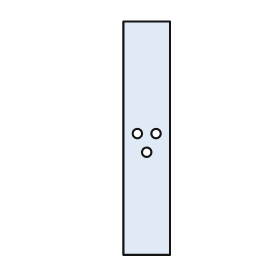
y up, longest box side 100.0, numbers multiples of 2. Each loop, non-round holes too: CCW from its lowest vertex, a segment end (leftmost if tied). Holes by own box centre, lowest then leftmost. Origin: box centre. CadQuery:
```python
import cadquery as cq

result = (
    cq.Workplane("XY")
    .moveTo(-10.0, -50.0)
    .lineTo(10.0, -50.0)
    .lineTo(10.0, 50.0)
    .lineTo(-10.0, 50.0)
    .close()
    .moveTo(0.0, -6.0)
    .circle(2.0)
    .moveTo(-4.0, 2.0)
    .circle(2.0)
    .moveTo(4.0, 2.0)
    .circle(2.0)
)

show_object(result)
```